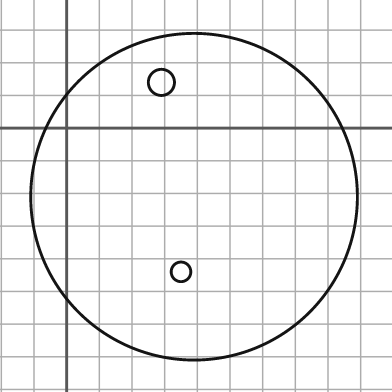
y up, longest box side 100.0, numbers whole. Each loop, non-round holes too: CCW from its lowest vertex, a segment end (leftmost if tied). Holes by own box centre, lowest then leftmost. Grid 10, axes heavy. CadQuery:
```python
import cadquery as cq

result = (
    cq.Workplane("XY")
    .moveTo(39.0, -21.0)
    .circle(50.0)
    .moveTo(35.0, -44.0)
    .circle(3.0)
    .moveTo(29.0, 14.0)
    .circle(4.0)
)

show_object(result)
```